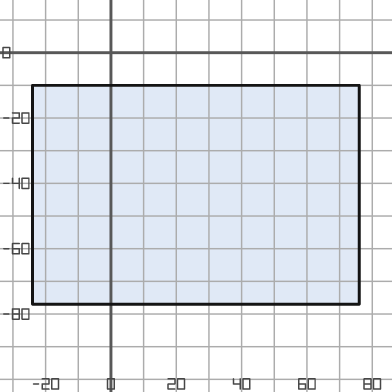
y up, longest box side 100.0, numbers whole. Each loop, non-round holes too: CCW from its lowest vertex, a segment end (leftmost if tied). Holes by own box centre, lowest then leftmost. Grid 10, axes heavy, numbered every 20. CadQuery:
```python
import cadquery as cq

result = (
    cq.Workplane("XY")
    .moveTo(-24.0, -77.0)
    .lineTo(76.0, -77.0)
    .lineTo(76.0, -10.0)
    .lineTo(-24.0, -10.0)
    .close()
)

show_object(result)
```